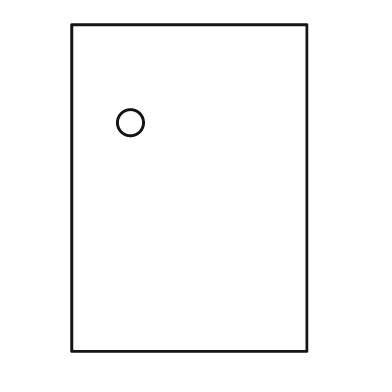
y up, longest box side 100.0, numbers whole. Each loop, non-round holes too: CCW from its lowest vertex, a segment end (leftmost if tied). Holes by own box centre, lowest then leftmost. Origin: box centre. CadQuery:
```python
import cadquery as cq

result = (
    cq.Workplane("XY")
    .moveTo(-36.0, -50.0)
    .lineTo(36.0, -50.0)
    .lineTo(36.0, 50.0)
    .lineTo(-36.0, 50.0)
    .close()
    .moveTo(-18.0, 20.0)
    .circle(4.0)
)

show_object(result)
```